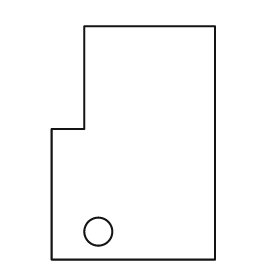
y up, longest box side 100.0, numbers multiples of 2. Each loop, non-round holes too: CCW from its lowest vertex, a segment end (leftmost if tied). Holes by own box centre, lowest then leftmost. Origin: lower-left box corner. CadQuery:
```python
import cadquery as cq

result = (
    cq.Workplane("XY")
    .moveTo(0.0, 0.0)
    .lineTo(70.0, 0.0)
    .lineTo(70.0, 100.0)
    .lineTo(14.0, 100.0)
    .lineTo(14.0, 56.0)
    .lineTo(0.0, 56.0)
    .close()
    .moveTo(20.0, 12.0)
    .circle(6.0)
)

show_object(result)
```